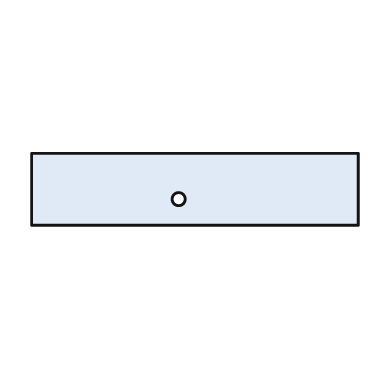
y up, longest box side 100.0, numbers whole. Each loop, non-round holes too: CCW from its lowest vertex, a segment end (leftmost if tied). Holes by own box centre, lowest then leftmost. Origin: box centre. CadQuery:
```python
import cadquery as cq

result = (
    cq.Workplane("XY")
    .moveTo(-50.0, -11.0)
    .lineTo(50.0, -11.0)
    .lineTo(50.0, 11.0)
    .lineTo(-50.0, 11.0)
    .close()
    .moveTo(-5.0, -3.0)
    .circle(2.0)
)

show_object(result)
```